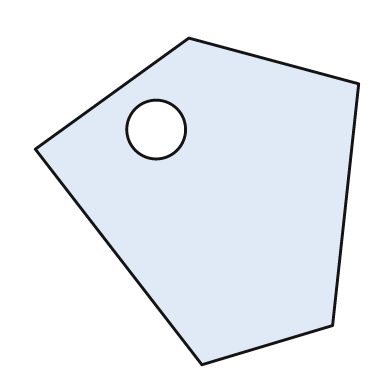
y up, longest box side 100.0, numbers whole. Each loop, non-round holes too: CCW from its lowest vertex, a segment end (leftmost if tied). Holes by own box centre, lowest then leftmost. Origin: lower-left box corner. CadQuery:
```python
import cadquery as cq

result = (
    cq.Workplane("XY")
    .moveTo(51.0, 0.0)
    .lineTo(91.0, 12.0)
    .lineTo(99.0, 86.0)
    .lineTo(47.0, 100.0)
    .lineTo(0.0, 66.0)
    .close()
    .moveTo(37.0, 72.0)
    .circle(9.0)
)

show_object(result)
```